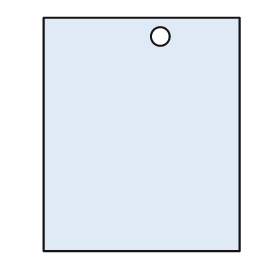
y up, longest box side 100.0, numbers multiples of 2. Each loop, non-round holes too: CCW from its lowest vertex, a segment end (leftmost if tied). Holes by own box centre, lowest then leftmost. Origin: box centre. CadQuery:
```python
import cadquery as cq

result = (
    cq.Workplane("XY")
    .moveTo(-42.0, -50.0)
    .lineTo(42.0, -50.0)
    .lineTo(42.0, 50.0)
    .lineTo(-42.0, 50.0)
    .close()
    .moveTo(8.0, 42.0)
    .circle(4.0)
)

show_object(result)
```